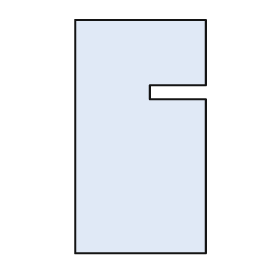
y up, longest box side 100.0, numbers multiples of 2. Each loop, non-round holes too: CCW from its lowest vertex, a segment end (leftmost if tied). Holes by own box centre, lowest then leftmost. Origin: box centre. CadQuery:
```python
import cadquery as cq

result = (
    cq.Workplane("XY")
    .moveTo(-28.0, -50.0)
    .lineTo(28.0, -50.0)
    .lineTo(28.0, 16.0)
    .lineTo(4.0, 16.0)
    .lineTo(4.0, 22.0)
    .lineTo(28.0, 22.0)
    .lineTo(28.0, 50.0)
    .lineTo(-28.0, 50.0)
    .close()
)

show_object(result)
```